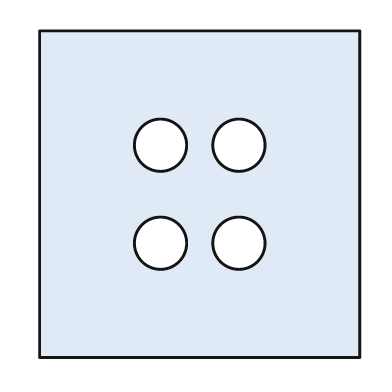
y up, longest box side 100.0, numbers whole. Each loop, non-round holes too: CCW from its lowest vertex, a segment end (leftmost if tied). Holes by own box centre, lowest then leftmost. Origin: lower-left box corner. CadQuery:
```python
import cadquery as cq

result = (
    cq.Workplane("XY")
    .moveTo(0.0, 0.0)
    .lineTo(98.0, 0.0)
    .lineTo(98.0, 100.0)
    .lineTo(0.0, 100.0)
    .close()
    .moveTo(37.0, 35.0)
    .circle(8.0)
    .moveTo(61.0, 35.0)
    .circle(8.0)
    .moveTo(37.0, 65.0)
    .circle(8.0)
    .moveTo(61.0, 65.0)
    .circle(8.0)
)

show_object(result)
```